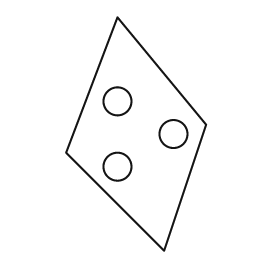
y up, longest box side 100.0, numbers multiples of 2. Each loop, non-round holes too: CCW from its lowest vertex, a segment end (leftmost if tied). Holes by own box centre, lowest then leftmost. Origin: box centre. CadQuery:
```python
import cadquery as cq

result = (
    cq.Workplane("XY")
    .moveTo(12.0, -50.0)
    .lineTo(30.0, 4.0)
    .lineTo(-8.0, 50.0)
    .lineTo(-30.0, -8.0)
    .close()
    .moveTo(-8.0, -14.0)
    .circle(6.0)
    .moveTo(16.0, 0.0)
    .circle(6.0)
    .moveTo(-8.0, 14.0)
    .circle(6.0)
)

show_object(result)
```